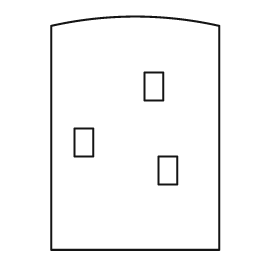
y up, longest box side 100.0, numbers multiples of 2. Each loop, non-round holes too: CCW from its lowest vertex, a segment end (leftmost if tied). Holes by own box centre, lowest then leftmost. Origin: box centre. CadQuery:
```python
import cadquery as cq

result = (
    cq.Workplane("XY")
    .moveTo(-36.0, -50.0)
    .lineTo(36.0, -50.0)
    .lineTo(36.0, 46.0)
    .threePointArc((0.0, 50.0), (-36.0, 46.0))
    .close()
    .moveTo(10.0, -22.0)
    .lineTo(18.0, -22.0)
    .lineTo(18.0, -10.0)
    .lineTo(10.0, -10.0)
    .close()
    .moveTo(-26.0, -10.0)
    .lineTo(-18.0, -10.0)
    .lineTo(-18.0, 2.0)
    .lineTo(-26.0, 2.0)
    .close()
    .moveTo(4.0, 14.0)
    .lineTo(12.0, 14.0)
    .lineTo(12.0, 26.0)
    .lineTo(4.0, 26.0)
    .close()
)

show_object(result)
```